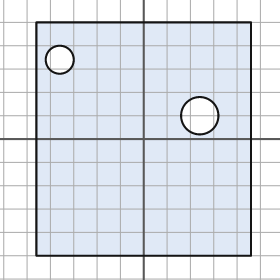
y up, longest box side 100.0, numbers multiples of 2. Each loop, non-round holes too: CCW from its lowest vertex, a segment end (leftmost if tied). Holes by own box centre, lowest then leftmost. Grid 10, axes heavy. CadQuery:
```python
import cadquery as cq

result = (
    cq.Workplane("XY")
    .moveTo(-46.0, -50.0)
    .lineTo(46.0, -50.0)
    .lineTo(46.0, 50.0)
    .lineTo(-46.0, 50.0)
    .close()
    .moveTo(24.0, 10.0)
    .circle(8.0)
    .moveTo(-36.0, 34.0)
    .circle(6.0)
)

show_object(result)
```